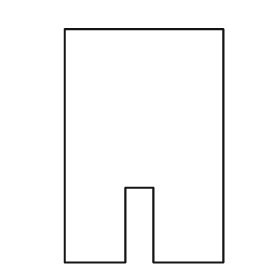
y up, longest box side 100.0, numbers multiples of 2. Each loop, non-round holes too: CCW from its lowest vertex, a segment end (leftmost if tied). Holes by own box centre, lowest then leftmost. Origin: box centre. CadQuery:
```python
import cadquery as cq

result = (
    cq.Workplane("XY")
    .moveTo(-34.0, -50.0)
    .lineTo(-8.0, -50.0)
    .lineTo(-8.0, -18.0)
    .lineTo(4.0, -18.0)
    .lineTo(4.0, -50.0)
    .lineTo(34.0, -50.0)
    .lineTo(34.0, 50.0)
    .lineTo(-34.0, 50.0)
    .close()
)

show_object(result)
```